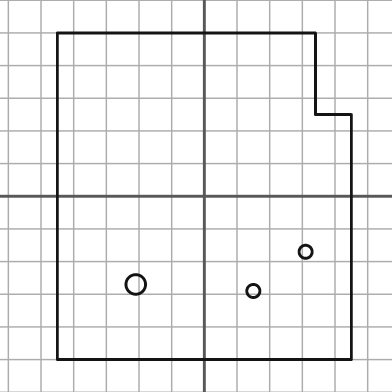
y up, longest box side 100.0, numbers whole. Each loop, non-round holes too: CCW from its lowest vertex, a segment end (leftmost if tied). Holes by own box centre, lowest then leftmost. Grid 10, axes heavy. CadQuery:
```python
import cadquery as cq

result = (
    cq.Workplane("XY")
    .moveTo(-45.0, -50.0)
    .lineTo(45.0, -50.0)
    .lineTo(45.0, 25.0)
    .lineTo(34.0, 25.0)
    .lineTo(34.0, 50.0)
    .lineTo(-45.0, 50.0)
    .close()
    .moveTo(15.0, -29.0)
    .circle(2.0)
    .moveTo(-21.0, -27.0)
    .circle(3.0)
    .moveTo(31.0, -17.0)
    .circle(2.0)
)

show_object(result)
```